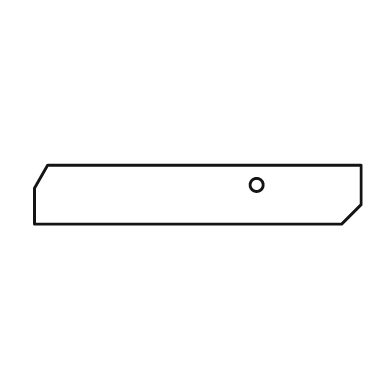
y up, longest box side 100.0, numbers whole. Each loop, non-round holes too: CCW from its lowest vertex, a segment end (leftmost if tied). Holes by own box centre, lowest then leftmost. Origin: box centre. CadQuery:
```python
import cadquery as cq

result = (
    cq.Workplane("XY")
    .moveTo(-50.0, -9.0)
    .lineTo(44.0, -9.0)
    .lineTo(50.0, -3.0)
    .lineTo(50.0, 9.0)
    .lineTo(-46.0, 9.0)
    .lineTo(-50.0, 2.0)
    .close()
    .moveTo(18.0, 3.0)
    .circle(2.0)
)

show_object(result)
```